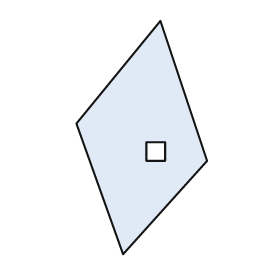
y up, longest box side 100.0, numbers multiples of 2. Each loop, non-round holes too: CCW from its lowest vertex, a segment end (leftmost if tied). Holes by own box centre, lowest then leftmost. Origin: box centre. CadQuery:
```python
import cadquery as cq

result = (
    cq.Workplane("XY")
    .moveTo(-8.0, -50.0)
    .lineTo(28.0, -10.0)
    .lineTo(8.0, 50.0)
    .lineTo(-28.0, 6.0)
    .close()
    .moveTo(2.0, -10.0)
    .lineTo(10.0, -10.0)
    .lineTo(10.0, -2.0)
    .lineTo(2.0, -2.0)
    .close()
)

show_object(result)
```